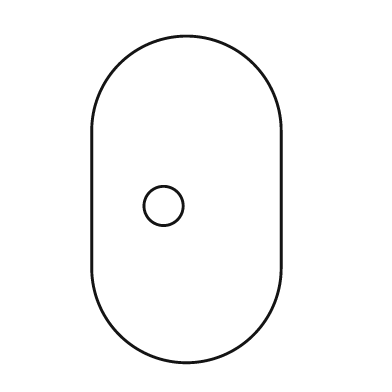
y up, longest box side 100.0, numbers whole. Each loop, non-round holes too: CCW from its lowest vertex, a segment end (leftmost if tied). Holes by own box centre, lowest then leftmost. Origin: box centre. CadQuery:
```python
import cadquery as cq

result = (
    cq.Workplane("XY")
    .moveTo(-29.0, -21.0)
    .threePointArc((0.0, -50.0), (29.0, -21.0))
    .lineTo(29.0, 21.0)
    .threePointArc((0.0, 50.0), (-29.0, 21.0))
    .close()
    .moveTo(-7.0, -2.0)
    .circle(6.0)
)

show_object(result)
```